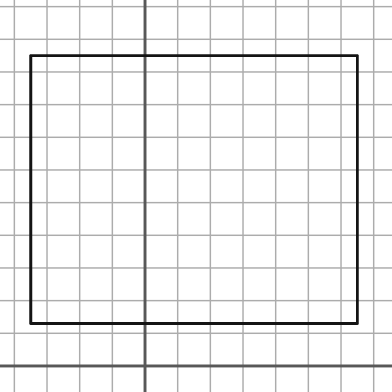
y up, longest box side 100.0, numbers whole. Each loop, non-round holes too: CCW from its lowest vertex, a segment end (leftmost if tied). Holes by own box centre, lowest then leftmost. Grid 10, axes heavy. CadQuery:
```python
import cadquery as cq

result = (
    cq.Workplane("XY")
    .moveTo(-35.0, 13.0)
    .lineTo(65.0, 13.0)
    .lineTo(65.0, 95.0)
    .lineTo(-35.0, 95.0)
    .close()
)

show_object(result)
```